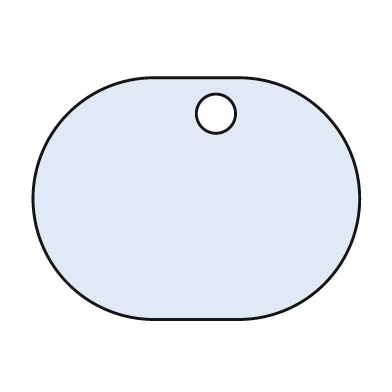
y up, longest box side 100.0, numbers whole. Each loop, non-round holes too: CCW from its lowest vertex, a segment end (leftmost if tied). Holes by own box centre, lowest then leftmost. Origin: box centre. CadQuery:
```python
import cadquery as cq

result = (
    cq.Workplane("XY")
    .moveTo(-13.0, -37.0)
    .lineTo(13.0, -37.0)
    .threePointArc((50.0, 0.0), (13.0, 37.0))
    .lineTo(-13.0, 37.0)
    .threePointArc((-50.0, 0.0), (-13.0, -37.0))
    .close()
    .moveTo(6.0, 26.0)
    .circle(6.0)
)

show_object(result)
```